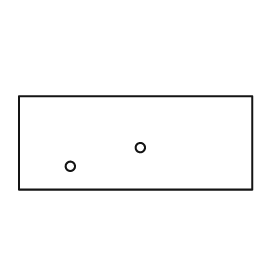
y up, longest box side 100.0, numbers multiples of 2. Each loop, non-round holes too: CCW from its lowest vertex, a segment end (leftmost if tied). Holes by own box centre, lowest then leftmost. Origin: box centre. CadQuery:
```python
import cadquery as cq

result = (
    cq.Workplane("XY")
    .moveTo(-50.0, -20.0)
    .lineTo(50.0, -20.0)
    .lineTo(50.0, 20.0)
    .lineTo(-50.0, 20.0)
    .close()
    .moveTo(-28.0, -10.0)
    .circle(2.0)
    .moveTo(2.0, -2.0)
    .circle(2.0)
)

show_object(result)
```